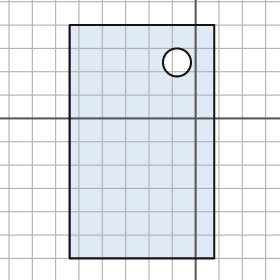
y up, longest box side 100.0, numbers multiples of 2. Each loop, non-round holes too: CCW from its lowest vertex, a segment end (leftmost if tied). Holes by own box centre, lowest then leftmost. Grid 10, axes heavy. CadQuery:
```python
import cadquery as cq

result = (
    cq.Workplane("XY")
    .moveTo(-54.0, -60.0)
    .lineTo(8.0, -60.0)
    .lineTo(8.0, 40.0)
    .lineTo(-54.0, 40.0)
    .close()
    .moveTo(-8.0, 24.0)
    .circle(6.0)
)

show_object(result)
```